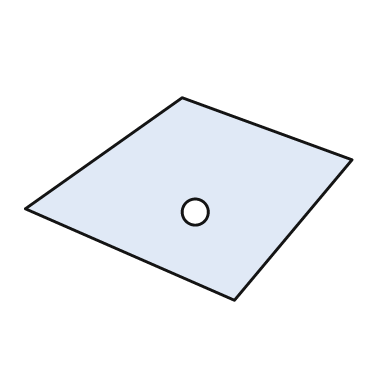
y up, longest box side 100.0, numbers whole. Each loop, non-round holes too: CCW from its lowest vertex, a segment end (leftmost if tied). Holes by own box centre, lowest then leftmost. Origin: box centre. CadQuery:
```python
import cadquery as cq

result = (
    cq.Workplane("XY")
    .moveTo(14.0, -31.0)
    .lineTo(50.0, 12.0)
    .lineTo(-2.0, 31.0)
    .lineTo(-50.0, -3.0)
    .close()
    .moveTo(2.0, -4.0)
    .circle(4.0)
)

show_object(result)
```